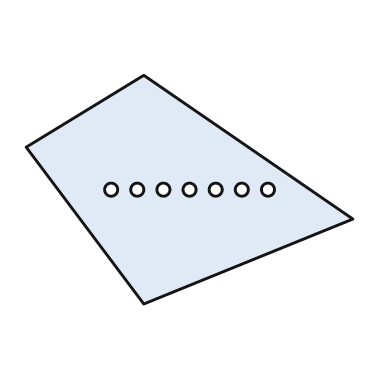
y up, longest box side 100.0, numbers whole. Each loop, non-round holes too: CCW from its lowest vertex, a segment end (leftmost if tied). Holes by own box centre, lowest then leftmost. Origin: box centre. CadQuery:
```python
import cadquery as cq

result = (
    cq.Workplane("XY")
    .moveTo(-14.0, -35.0)
    .lineTo(50.0, -9.0)
    .lineTo(-14.0, 35.0)
    .lineTo(-50.0, 13.0)
    .close()
    .moveTo(-24.0, 0.0)
    .circle(2.0)
    .moveTo(-16.0, 0.0)
    .circle(2.0)
    .moveTo(-8.0, 0.0)
    .circle(2.0)
    .moveTo(0.0, 0.0)
    .circle(2.0)
    .moveTo(8.0, 0.0)
    .circle(2.0)
    .moveTo(16.0, 0.0)
    .circle(2.0)
    .moveTo(24.0, 0.0)
    .circle(2.0)
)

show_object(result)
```